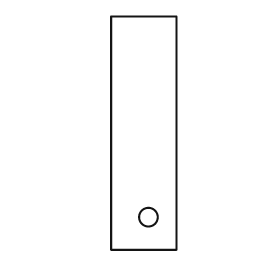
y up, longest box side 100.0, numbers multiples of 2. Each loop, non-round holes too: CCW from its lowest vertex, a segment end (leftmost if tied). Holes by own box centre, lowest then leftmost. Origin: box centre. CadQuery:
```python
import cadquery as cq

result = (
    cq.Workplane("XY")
    .moveTo(-14.0, -50.0)
    .lineTo(14.0, -50.0)
    .lineTo(14.0, 50.0)
    .lineTo(-14.0, 50.0)
    .close()
    .moveTo(2.0, -36.0)
    .circle(4.0)
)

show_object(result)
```